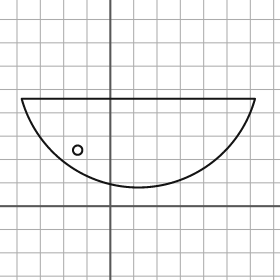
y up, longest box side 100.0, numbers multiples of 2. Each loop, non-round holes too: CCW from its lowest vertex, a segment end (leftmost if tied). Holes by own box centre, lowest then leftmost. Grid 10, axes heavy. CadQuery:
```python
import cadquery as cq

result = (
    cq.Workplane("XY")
    .moveTo(-38.0, 46.0)
    .threePointArc((12.0, 8.0), (62.0, 46.0))
    .close()
    .moveTo(-14.0, 24.0)
    .circle(2.0)
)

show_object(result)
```